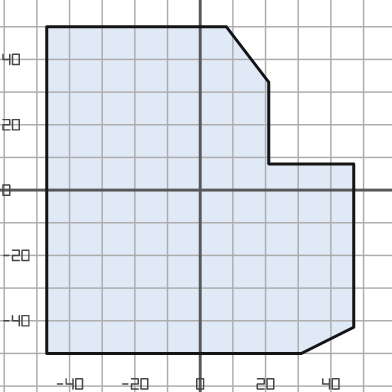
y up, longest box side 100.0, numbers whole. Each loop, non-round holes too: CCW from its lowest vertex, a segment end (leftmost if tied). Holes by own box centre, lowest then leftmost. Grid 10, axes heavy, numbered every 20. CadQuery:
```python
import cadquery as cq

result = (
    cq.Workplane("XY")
    .moveTo(-47.0, -50.0)
    .lineTo(31.0, -50.0)
    .lineTo(47.0, -42.0)
    .lineTo(47.0, 8.0)
    .lineTo(21.0, 8.0)
    .lineTo(21.0, 33.0)
    .lineTo(8.0, 50.0)
    .lineTo(-47.0, 50.0)
    .close()
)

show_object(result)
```